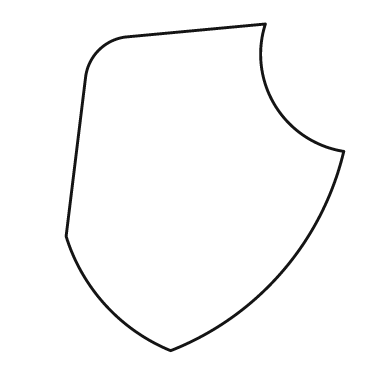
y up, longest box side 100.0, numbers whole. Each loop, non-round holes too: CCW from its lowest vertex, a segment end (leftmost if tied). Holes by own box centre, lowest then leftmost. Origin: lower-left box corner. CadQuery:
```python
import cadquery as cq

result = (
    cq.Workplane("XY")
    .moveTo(32.0, 0.0)
    .threePointArc((66.0, 24.0), (85.0, 61.0))
    .threePointArc((64.0, 75.0), (61.0, 100.0))
    .lineTo(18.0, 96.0)
    .threePointArc((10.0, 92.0), (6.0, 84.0))
    .lineTo(0.0, 35.0)
    .threePointArc((12.0, 14.0), (32.0, 0.0))
    .close()
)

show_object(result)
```